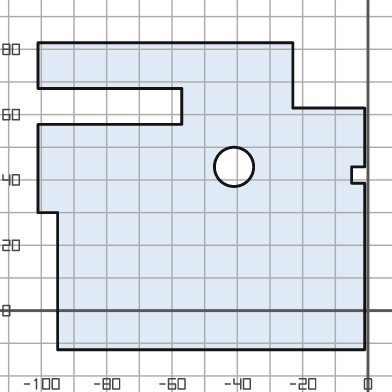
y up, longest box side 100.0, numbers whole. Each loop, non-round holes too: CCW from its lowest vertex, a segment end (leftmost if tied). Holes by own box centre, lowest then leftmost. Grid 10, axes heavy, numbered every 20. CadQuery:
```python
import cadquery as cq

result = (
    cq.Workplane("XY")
    .moveTo(-95.0, -12.0)
    .lineTo(-1.0, -12.0)
    .lineTo(-1.0, 39.0)
    .lineTo(-5.0, 39.0)
    .lineTo(-5.0, 44.0)
    .lineTo(-1.0, 44.0)
    .lineTo(-1.0, 62.0)
    .lineTo(-23.0, 62.0)
    .lineTo(-23.0, 82.0)
    .lineTo(-101.0, 82.0)
    .lineTo(-101.0, 68.0)
    .lineTo(-57.0, 68.0)
    .lineTo(-57.0, 57.0)
    .lineTo(-101.0, 57.0)
    .lineTo(-101.0, 30.0)
    .lineTo(-95.0, 30.0)
    .close()
    .moveTo(-41.0, 44.0)
    .circle(6.0)
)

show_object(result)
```